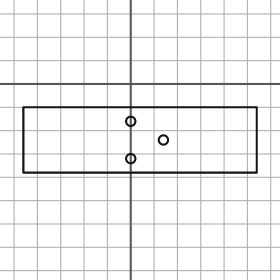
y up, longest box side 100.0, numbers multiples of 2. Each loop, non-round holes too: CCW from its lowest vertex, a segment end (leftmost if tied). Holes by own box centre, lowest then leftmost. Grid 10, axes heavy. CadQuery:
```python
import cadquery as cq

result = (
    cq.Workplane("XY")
    .moveTo(-46.0, -38.0)
    .lineTo(54.0, -38.0)
    .lineTo(54.0, -10.0)
    .lineTo(-46.0, -10.0)
    .close()
    .moveTo(0.0, -32.0)
    .circle(2.0)
    .moveTo(14.0, -24.0)
    .circle(2.0)
    .moveTo(0.0, -16.0)
    .circle(2.0)
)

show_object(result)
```